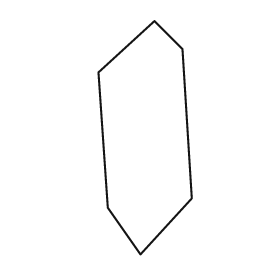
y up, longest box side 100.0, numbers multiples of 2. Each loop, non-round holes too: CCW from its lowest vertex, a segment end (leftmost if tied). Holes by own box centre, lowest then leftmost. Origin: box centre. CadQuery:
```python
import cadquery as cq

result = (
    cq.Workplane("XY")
    .moveTo(-2.0, -50.0)
    .lineTo(20.0, -26.0)
    .lineTo(16.0, 38.0)
    .lineTo(4.0, 50.0)
    .lineTo(-20.0, 28.0)
    .lineTo(-16.0, -30.0)
    .close()
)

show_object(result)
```